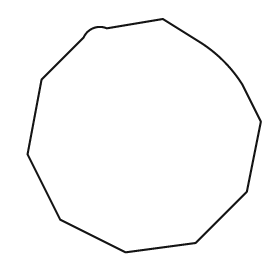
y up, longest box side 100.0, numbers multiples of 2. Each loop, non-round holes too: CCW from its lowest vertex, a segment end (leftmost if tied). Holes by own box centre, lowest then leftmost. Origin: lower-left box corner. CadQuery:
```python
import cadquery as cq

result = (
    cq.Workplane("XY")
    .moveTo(42.0, 0.0)
    .lineTo(72.0, 4.0)
    .lineTo(94.0, 26.0)
    .lineTo(100.0, 56.0)
    .lineTo(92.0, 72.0)
    .threePointArc((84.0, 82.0), (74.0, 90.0))
    .lineTo(58.0, 100.0)
    .lineTo(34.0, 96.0)
    .threePointArc((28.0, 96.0), (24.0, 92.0))
    .lineTo(6.0, 74.0)
    .lineTo(0.0, 42.0)
    .lineTo(14.0, 14.0)
    .close()
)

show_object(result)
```